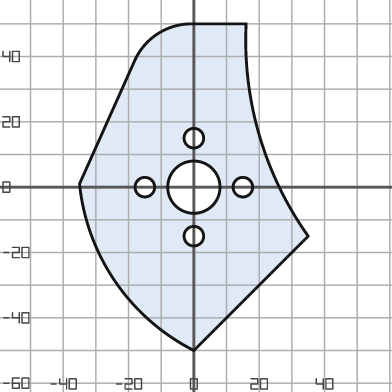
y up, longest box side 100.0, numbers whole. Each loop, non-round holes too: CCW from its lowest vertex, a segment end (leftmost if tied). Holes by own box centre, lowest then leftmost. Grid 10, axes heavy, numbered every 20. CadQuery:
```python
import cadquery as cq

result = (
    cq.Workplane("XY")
    .moveTo(0.0, -50.0)
    .lineTo(35.0, -15.0)
    .threePointArc((20.0, 16.0), (16.0, 50.0))
    .lineTo(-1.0, 50.0)
    .threePointArc((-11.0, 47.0), (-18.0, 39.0))
    .lineTo(-35.0, 1.0)
    .threePointArc((-24.0, -29.0), (0.0, -50.0))
    .close()
    .moveTo(0.0, -15.0)
    .circle(3.0)
    .moveTo(-15.0, 0.0)
    .circle(3.0)
    .moveTo(0.0, 0.0)
    .circle(8.0)
    .moveTo(15.0, 0.0)
    .circle(3.0)
    .moveTo(0.0, 15.0)
    .circle(3.0)
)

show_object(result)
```